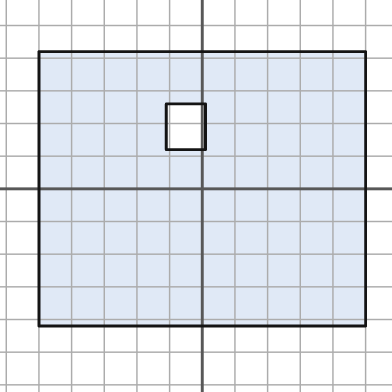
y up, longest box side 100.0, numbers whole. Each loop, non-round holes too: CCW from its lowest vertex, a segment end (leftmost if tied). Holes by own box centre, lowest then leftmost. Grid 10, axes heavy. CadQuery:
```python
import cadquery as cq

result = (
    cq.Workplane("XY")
    .moveTo(-50.0, -42.0)
    .lineTo(50.0, -42.0)
    .lineTo(50.0, 42.0)
    .lineTo(-50.0, 42.0)
    .close()
    .moveTo(-11.0, 12.0)
    .lineTo(1.0, 12.0)
    .lineTo(1.0, 26.0)
    .lineTo(-11.0, 26.0)
    .close()
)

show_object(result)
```